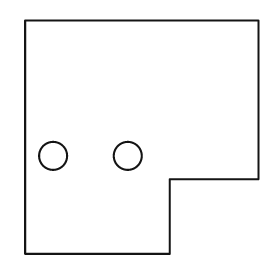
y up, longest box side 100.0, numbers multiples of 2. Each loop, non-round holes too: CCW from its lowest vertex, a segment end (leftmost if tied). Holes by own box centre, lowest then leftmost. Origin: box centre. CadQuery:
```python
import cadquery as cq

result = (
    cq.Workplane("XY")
    .moveTo(-50.0, -50.0)
    .lineTo(12.0, -50.0)
    .lineTo(12.0, -18.0)
    .lineTo(50.0, -18.0)
    .lineTo(50.0, 50.0)
    .lineTo(-50.0, 50.0)
    .close()
    .moveTo(-38.0, -8.0)
    .circle(6.0)
    .moveTo(-6.0, -8.0)
    .circle(6.0)
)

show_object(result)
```